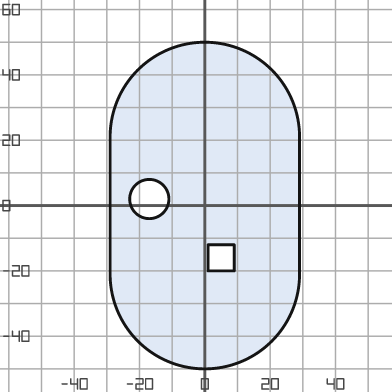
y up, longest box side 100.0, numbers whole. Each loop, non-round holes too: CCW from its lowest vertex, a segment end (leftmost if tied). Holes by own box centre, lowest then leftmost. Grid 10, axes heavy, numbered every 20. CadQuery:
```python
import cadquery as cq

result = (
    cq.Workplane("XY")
    .moveTo(-29.0, -21.0)
    .threePointArc((0.0, -50.0), (29.0, -21.0))
    .lineTo(29.0, 21.0)
    .threePointArc((0.0, 50.0), (-29.0, 21.0))
    .close()
    .moveTo(1.0, -20.0)
    .lineTo(9.0, -20.0)
    .lineTo(9.0, -12.0)
    .lineTo(1.0, -12.0)
    .close()
    .moveTo(-17.0, 2.0)
    .circle(6.0)
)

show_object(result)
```